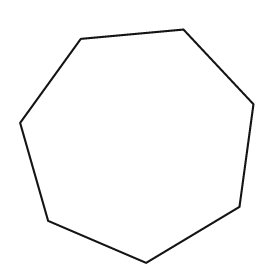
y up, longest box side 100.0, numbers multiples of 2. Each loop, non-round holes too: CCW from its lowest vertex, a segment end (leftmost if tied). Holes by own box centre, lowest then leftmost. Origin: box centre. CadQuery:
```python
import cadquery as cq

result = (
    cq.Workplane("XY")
    .moveTo(4.0, -50.0)
    .lineTo(44.0, -26.0)
    .lineTo(50.0, 18.0)
    .lineTo(20.0, 50.0)
    .lineTo(-24.0, 46.0)
    .lineTo(-50.0, 10.0)
    .lineTo(-38.0, -32.0)
    .close()
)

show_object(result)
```